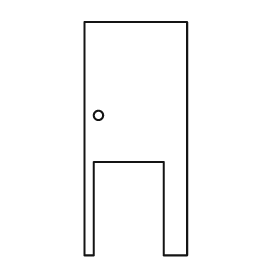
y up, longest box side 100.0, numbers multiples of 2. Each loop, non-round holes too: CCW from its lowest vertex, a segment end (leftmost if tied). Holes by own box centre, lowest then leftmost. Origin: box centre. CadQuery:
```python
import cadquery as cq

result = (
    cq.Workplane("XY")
    .moveTo(-22.0, -50.0)
    .lineTo(-18.0, -50.0)
    .lineTo(-18.0, -10.0)
    .lineTo(12.0, -10.0)
    .lineTo(12.0, -50.0)
    .lineTo(22.0, -50.0)
    .lineTo(22.0, 50.0)
    .lineTo(-22.0, 50.0)
    .close()
    .moveTo(-16.0, 10.0)
    .circle(2.0)
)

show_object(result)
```